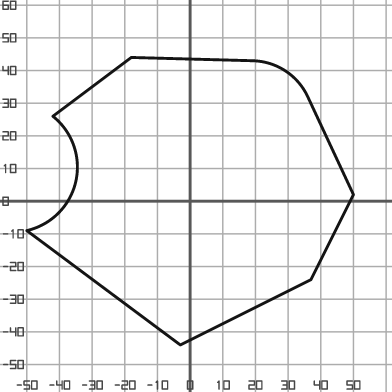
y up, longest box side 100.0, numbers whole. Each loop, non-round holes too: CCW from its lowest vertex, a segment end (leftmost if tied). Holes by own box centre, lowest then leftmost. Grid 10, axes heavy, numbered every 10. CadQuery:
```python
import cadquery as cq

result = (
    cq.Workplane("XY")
    .moveTo(-3.0, -44.0)
    .lineTo(37.0, -24.0)
    .lineTo(50.0, 2.0)
    .lineTo(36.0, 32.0)
    .threePointArc((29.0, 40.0), (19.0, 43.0))
    .lineTo(-18.0, 44.0)
    .lineTo(-42.0, 26.0)
    .threePointArc((-35.0, 6.0), (-50.0, -9.0))
    .close()
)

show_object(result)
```